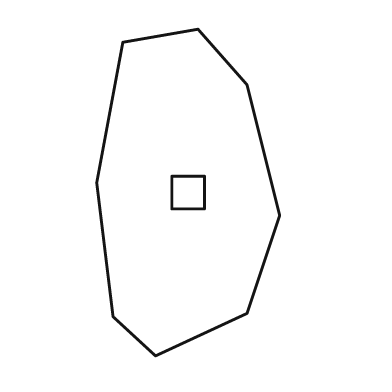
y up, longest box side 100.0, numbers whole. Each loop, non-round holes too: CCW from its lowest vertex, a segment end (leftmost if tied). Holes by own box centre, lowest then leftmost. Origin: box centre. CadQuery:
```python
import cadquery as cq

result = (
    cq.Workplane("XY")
    .moveTo(-10.0, -50.0)
    .lineTo(18.0, -37.0)
    .lineTo(28.0, -7.0)
    .lineTo(18.0, 33.0)
    .lineTo(3.0, 50.0)
    .lineTo(-20.0, 46.0)
    .lineTo(-28.0, 3.0)
    .lineTo(-23.0, -38.0)
    .close()
    .moveTo(-5.0, -5.0)
    .lineTo(5.0, -5.0)
    .lineTo(5.0, 5.0)
    .lineTo(-5.0, 5.0)
    .close()
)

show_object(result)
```